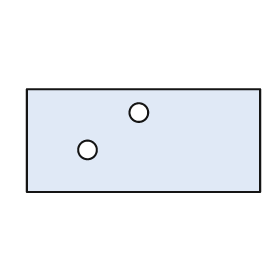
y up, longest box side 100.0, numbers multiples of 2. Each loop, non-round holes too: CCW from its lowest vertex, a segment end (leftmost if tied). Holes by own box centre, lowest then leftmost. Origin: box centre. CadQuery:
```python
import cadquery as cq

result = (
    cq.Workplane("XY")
    .moveTo(-50.0, -22.0)
    .lineTo(50.0, -22.0)
    .lineTo(50.0, 22.0)
    .lineTo(-50.0, 22.0)
    .close()
    .moveTo(-24.0, -4.0)
    .circle(4.0)
    .moveTo(-2.0, 12.0)
    .circle(4.0)
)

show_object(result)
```